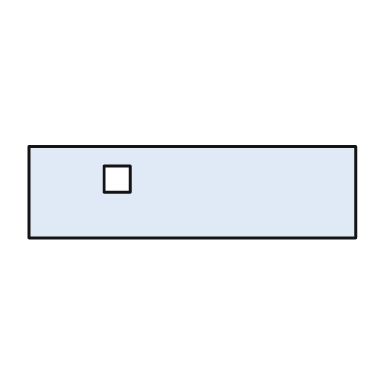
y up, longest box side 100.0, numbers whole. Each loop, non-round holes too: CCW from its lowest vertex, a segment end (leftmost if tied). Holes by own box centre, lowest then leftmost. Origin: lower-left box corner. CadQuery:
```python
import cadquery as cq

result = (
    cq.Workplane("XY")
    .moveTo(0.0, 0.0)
    .lineTo(100.0, 0.0)
    .lineTo(100.0, 28.0)
    .lineTo(0.0, 28.0)
    .close()
    .moveTo(23.0, 14.0)
    .lineTo(31.0, 14.0)
    .lineTo(31.0, 22.0)
    .lineTo(23.0, 22.0)
    .close()
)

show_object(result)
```